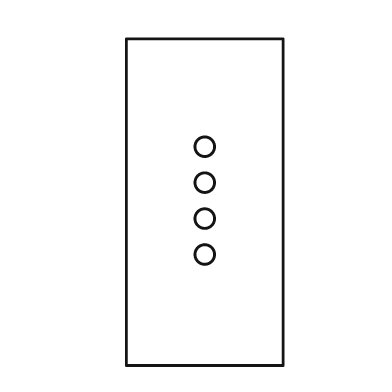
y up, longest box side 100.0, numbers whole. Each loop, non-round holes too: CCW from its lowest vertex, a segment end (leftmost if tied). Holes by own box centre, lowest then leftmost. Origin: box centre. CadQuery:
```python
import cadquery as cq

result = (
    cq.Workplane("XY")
    .moveTo(-24.0, -50.0)
    .lineTo(24.0, -50.0)
    .lineTo(24.0, 50.0)
    .lineTo(-24.0, 50.0)
    .close()
    .moveTo(0.0, -16.0)
    .circle(3.0)
    .moveTo(0.0, -5.0)
    .circle(3.0)
    .moveTo(0.0, 6.0)
    .circle(3.0)
    .moveTo(0.0, 17.0)
    .circle(3.0)
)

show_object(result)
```